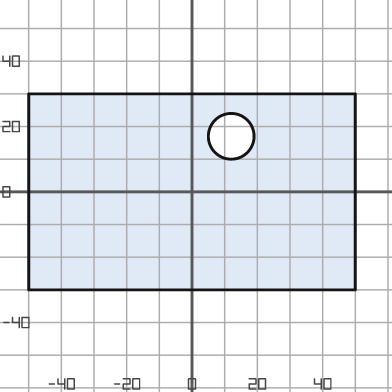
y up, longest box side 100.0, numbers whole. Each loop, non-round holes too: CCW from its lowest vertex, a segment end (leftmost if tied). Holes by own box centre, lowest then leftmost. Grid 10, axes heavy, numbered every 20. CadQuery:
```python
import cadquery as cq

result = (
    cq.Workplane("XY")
    .moveTo(-50.0, -30.0)
    .lineTo(50.0, -30.0)
    .lineTo(50.0, 30.0)
    .lineTo(-50.0, 30.0)
    .close()
    .moveTo(12.0, 17.0)
    .circle(7.0)
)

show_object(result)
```